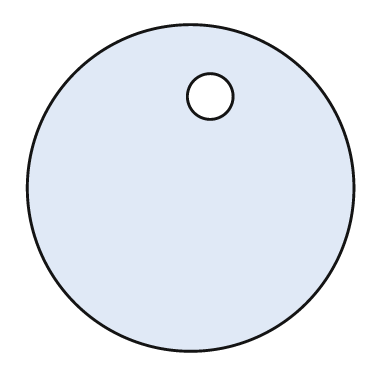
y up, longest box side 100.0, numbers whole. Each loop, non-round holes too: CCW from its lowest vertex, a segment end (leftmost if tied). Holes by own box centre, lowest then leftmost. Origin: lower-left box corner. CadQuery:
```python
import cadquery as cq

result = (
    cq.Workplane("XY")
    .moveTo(50.0, 50.0)
    .circle(50.0)
    .moveTo(56.0, 78.0)
    .circle(7.0)
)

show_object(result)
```